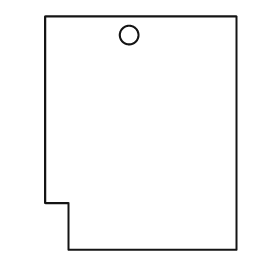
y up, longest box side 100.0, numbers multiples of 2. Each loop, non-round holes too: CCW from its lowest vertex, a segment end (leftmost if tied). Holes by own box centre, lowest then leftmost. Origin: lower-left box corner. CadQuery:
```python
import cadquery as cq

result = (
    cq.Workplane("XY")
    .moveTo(10.0, 0.0)
    .lineTo(82.0, 0.0)
    .lineTo(82.0, 100.0)
    .lineTo(0.0, 100.0)
    .lineTo(0.0, 20.0)
    .lineTo(10.0, 20.0)
    .close()
    .moveTo(36.0, 92.0)
    .circle(4.0)
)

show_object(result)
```